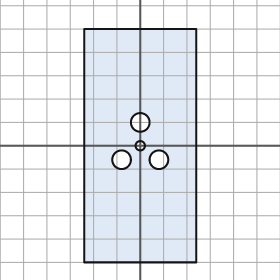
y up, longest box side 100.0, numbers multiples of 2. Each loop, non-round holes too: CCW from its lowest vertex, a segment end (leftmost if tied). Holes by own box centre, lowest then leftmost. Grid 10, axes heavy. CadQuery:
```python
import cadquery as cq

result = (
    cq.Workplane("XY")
    .moveTo(-24.0, -50.0)
    .lineTo(24.0, -50.0)
    .lineTo(24.0, 50.0)
    .lineTo(-24.0, 50.0)
    .close()
    .moveTo(-8.0, -6.0)
    .circle(4.0)
    .moveTo(8.0, -6.0)
    .circle(4.0)
    .moveTo(0.0, 0.0)
    .circle(2.0)
    .moveTo(0.0, 10.0)
    .circle(4.0)
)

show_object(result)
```